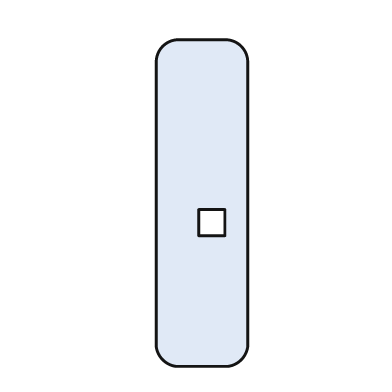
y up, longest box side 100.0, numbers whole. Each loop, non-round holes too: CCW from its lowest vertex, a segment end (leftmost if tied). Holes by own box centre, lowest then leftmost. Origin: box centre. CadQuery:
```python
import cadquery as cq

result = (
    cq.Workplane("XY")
    .moveTo(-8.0, -50.0)
    .lineTo(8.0, -50.0)
    .threePointArc((12.0, -48.0), (14.0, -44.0))
    .lineTo(14.0, 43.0)
    .threePointArc((12.0, 48.0), (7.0, 50.0))
    .lineTo(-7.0, 50.0)
    .threePointArc((-12.0, 48.0), (-14.0, 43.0))
    .lineTo(-14.0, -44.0)
    .threePointArc((-12.0, -48.0), (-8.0, -50.0))
    .close()
    .moveTo(-1.0, -10.0)
    .lineTo(7.0, -10.0)
    .lineTo(7.0, -2.0)
    .lineTo(-1.0, -2.0)
    .close()
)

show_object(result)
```